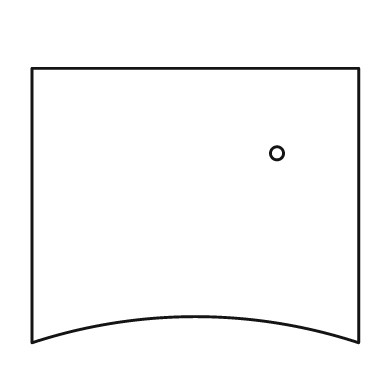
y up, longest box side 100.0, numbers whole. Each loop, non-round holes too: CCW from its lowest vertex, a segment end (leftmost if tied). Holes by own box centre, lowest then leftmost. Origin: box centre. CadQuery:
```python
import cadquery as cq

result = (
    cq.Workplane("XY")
    .moveTo(-50.0, -42.0)
    .threePointArc((0.0, -34.0), (50.0, -42.0))
    .lineTo(50.0, 42.0)
    .lineTo(-50.0, 42.0)
    .close()
    .moveTo(25.0, 16.0)
    .circle(2.0)
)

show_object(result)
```